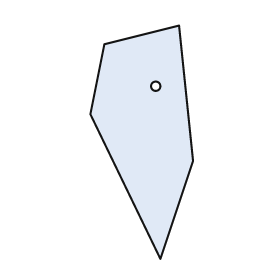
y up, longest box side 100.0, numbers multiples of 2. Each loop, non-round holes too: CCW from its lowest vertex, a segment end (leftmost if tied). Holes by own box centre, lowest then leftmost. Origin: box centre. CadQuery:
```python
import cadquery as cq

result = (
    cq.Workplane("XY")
    .moveTo(8.0, -50.0)
    .lineTo(22.0, -8.0)
    .lineTo(16.0, 50.0)
    .lineTo(-16.0, 42.0)
    .lineTo(-22.0, 12.0)
    .close()
    .moveTo(6.0, 24.0)
    .circle(2.0)
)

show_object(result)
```